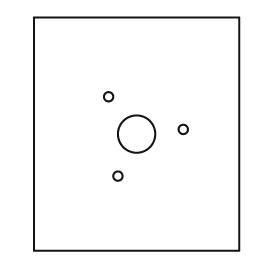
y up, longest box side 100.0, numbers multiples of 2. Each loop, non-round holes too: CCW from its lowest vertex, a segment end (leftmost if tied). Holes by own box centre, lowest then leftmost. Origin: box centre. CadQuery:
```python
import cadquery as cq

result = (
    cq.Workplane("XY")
    .moveTo(-44.0, -50.0)
    .lineTo(44.0, -50.0)
    .lineTo(44.0, 50.0)
    .lineTo(-44.0, 50.0)
    .close()
    .moveTo(-8.0, -18.0)
    .circle(2.0)
    .moveTo(0.0, 0.0)
    .circle(8.0)
    .moveTo(20.0, 2.0)
    .circle(2.0)
    .moveTo(-12.0, 16.0)
    .circle(2.0)
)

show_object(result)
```